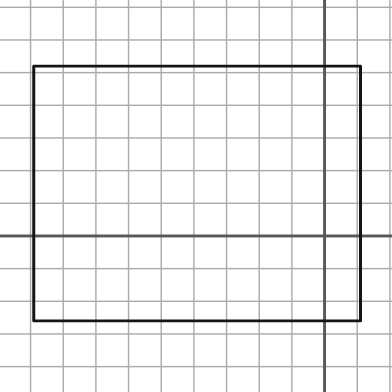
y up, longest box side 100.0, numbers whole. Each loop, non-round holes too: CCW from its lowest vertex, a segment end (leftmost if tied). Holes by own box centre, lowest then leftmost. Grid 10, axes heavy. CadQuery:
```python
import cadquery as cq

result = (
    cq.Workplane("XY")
    .moveTo(-89.0, -26.0)
    .lineTo(11.0, -26.0)
    .lineTo(11.0, 52.0)
    .lineTo(-89.0, 52.0)
    .close()
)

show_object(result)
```